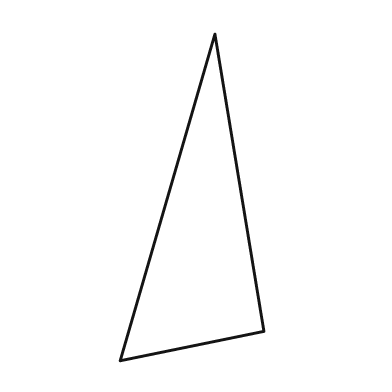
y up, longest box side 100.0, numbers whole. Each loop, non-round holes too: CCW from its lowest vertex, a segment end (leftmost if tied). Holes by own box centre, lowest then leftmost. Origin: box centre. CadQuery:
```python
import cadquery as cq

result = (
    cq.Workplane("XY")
    .moveTo(-22.0, -50.0)
    .lineTo(22.0, -41.0)
    .lineTo(7.0, 50.0)
    .close()
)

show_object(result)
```